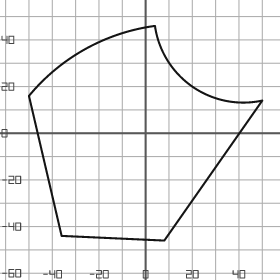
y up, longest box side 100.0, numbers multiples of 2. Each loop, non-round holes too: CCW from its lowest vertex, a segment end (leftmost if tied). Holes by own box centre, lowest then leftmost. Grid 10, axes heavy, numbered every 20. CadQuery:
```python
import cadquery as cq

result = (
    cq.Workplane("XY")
    .moveTo(8.0, -46.0)
    .lineTo(50.0, 14.0)
    .threePointArc((20.0, 20.0), (4.0, 46.0))
    .threePointArc((-26.0, 36.0), (-50.0, 16.0))
    .lineTo(-36.0, -44.0)
    .close()
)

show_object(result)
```